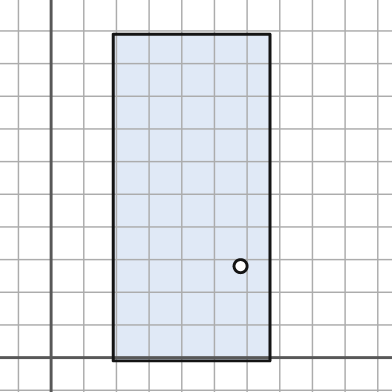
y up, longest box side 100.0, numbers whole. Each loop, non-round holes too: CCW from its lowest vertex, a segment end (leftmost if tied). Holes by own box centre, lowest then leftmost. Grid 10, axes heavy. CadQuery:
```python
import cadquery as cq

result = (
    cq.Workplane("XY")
    .moveTo(19.0, -1.0)
    .lineTo(67.0, -1.0)
    .lineTo(67.0, 99.0)
    .lineTo(19.0, 99.0)
    .close()
    .moveTo(58.0, 28.0)
    .circle(2.0)
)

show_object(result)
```